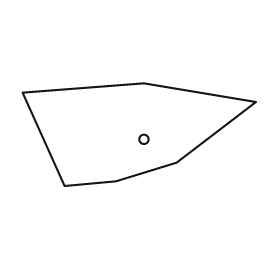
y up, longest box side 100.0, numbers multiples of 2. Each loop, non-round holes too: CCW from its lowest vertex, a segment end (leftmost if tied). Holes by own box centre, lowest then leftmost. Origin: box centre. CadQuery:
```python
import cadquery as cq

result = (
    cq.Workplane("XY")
    .moveTo(-32.0, -22.0)
    .lineTo(-10.0, -20.0)
    .lineTo(16.0, -12.0)
    .lineTo(50.0, 14.0)
    .lineTo(2.0, 22.0)
    .lineTo(-50.0, 18.0)
    .close()
    .moveTo(2.0, -2.0)
    .circle(2.0)
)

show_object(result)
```